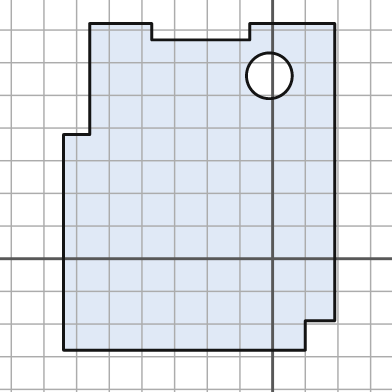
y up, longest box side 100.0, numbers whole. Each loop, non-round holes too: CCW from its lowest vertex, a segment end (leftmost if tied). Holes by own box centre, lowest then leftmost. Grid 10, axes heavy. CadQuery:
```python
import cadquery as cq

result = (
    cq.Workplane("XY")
    .moveTo(-64.0, -28.0)
    .lineTo(10.0, -28.0)
    .lineTo(10.0, -19.0)
    .lineTo(19.0, -19.0)
    .lineTo(19.0, 72.0)
    .lineTo(-7.0, 72.0)
    .lineTo(-7.0, 67.0)
    .lineTo(-37.0, 67.0)
    .lineTo(-37.0, 72.0)
    .lineTo(-56.0, 72.0)
    .lineTo(-56.0, 38.0)
    .lineTo(-64.0, 38.0)
    .close()
    .moveTo(-1.0, 56.0)
    .circle(7.0)
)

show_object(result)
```